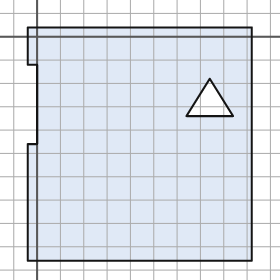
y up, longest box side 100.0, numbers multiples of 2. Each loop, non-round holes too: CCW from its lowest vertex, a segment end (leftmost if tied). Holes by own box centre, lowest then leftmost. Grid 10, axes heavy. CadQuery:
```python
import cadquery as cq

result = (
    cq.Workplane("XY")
    .moveTo(-4.0, -96.0)
    .lineTo(92.0, -96.0)
    .lineTo(92.0, 4.0)
    .lineTo(-4.0, 4.0)
    .lineTo(-4.0, -12.0)
    .lineTo(0.0, -12.0)
    .lineTo(0.0, -46.0)
    .lineTo(-4.0, -46.0)
    .close()
    .moveTo(64.0, -34.0)
    .lineTo(84.0, -34.0)
    .lineTo(74.0, -18.0)
    .close()
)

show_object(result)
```